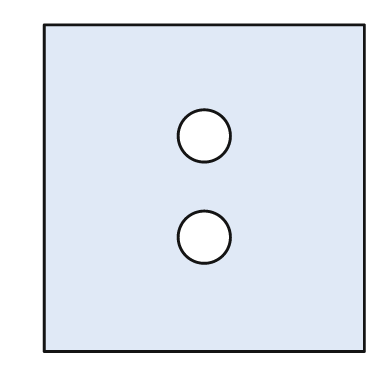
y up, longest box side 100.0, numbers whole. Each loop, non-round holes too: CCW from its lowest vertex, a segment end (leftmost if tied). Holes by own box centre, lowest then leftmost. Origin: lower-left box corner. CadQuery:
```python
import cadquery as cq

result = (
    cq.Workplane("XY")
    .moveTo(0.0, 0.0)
    .lineTo(98.0, 0.0)
    .lineTo(98.0, 100.0)
    .lineTo(0.0, 100.0)
    .close()
    .moveTo(49.0, 35.0)
    .circle(8.0)
    .moveTo(49.0, 66.0)
    .circle(8.0)
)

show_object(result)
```